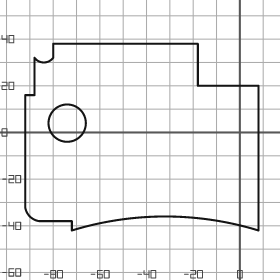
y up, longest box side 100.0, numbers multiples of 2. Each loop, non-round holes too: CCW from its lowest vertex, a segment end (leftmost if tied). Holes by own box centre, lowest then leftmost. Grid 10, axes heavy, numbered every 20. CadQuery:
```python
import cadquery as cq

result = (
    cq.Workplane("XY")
    .moveTo(-72.0, -42.0)
    .threePointArc((-32.0, -36.0), (8.0, -42.0))
    .lineTo(8.0, 20.0)
    .lineTo(-18.0, 20.0)
    .lineTo(-18.0, 38.0)
    .lineTo(-80.0, 38.0)
    .lineTo(-80.0, 32.0)
    .threePointArc((-84.0, 30.0), (-88.0, 32.0))
    .lineTo(-88.0, 16.0)
    .lineTo(-92.0, 16.0)
    .lineTo(-92.0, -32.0)
    .threePointArc((-90.0, -36.0), (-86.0, -38.0))
    .lineTo(-72.0, -38.0)
    .close()
    .moveTo(-74.0, 4.0)
    .circle(8.0)
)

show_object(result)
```